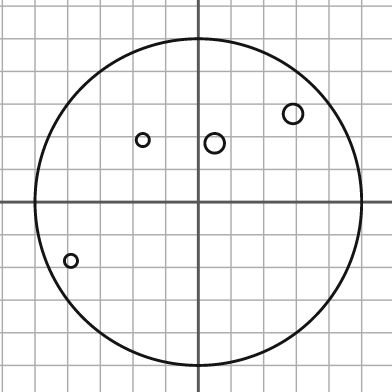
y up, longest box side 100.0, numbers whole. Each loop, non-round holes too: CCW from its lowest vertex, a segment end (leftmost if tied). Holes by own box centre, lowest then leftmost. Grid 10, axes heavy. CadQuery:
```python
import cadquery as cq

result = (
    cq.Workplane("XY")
    .moveTo(0.0, 0.0)
    .circle(50.0)
    .moveTo(-39.0, -18.0)
    .circle(2.0)
    .moveTo(5.0, 18.0)
    .circle(3.0)
    .moveTo(-17.0, 19.0)
    .circle(2.0)
    .moveTo(29.0, 27.0)
    .circle(3.0)
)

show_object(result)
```